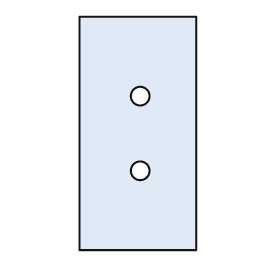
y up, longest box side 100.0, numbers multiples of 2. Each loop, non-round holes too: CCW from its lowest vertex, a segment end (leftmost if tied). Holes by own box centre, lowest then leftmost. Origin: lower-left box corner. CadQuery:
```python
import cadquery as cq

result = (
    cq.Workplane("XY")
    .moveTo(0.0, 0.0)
    .lineTo(50.0, 0.0)
    .lineTo(50.0, 100.0)
    .lineTo(0.0, 100.0)
    .close()
    .moveTo(26.0, 34.0)
    .circle(4.0)
    .moveTo(26.0, 66.0)
    .circle(4.0)
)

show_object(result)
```